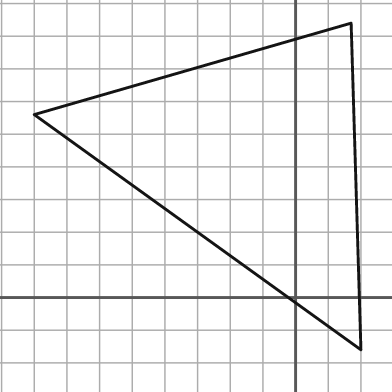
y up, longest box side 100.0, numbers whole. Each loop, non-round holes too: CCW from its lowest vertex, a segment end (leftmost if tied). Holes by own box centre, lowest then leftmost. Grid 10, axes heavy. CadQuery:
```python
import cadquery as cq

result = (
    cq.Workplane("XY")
    .moveTo(20.0, -16.0)
    .lineTo(17.0, 84.0)
    .lineTo(-80.0, 56.0)
    .close()
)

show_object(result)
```